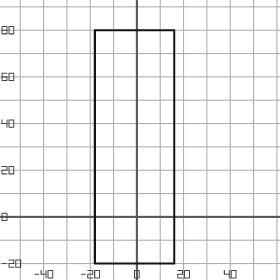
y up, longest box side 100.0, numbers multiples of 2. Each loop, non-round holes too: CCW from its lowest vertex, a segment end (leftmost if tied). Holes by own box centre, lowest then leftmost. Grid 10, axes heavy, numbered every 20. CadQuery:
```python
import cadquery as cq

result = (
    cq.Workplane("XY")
    .moveTo(-18.0, -20.0)
    .lineTo(16.0, -20.0)
    .lineTo(16.0, 80.0)
    .lineTo(-18.0, 80.0)
    .close()
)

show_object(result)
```